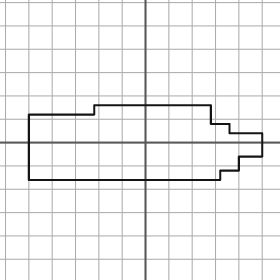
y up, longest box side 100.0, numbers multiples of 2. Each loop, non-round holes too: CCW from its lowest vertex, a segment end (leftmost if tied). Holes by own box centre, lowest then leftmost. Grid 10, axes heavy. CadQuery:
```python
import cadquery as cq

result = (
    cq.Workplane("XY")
    .moveTo(-50.0, -16.0)
    .lineTo(32.0, -16.0)
    .lineTo(32.0, -12.0)
    .lineTo(40.0, -12.0)
    .lineTo(40.0, -6.0)
    .lineTo(50.0, -6.0)
    .lineTo(50.0, 4.0)
    .lineTo(36.0, 4.0)
    .lineTo(36.0, 8.0)
    .lineTo(28.0, 8.0)
    .lineTo(28.0, 16.0)
    .lineTo(-22.0, 16.0)
    .lineTo(-22.0, 12.0)
    .lineTo(-50.0, 12.0)
    .close()
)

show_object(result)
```